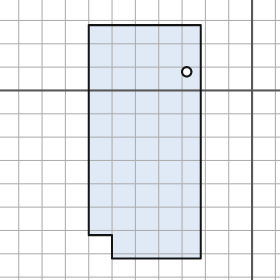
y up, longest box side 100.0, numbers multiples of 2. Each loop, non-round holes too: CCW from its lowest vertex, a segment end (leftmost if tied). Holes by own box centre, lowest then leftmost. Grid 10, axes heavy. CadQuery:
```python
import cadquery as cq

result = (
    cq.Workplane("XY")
    .moveTo(-60.0, -72.0)
    .lineTo(-22.0, -72.0)
    .lineTo(-22.0, 28.0)
    .lineTo(-70.0, 28.0)
    .lineTo(-70.0, -62.0)
    .lineTo(-60.0, -62.0)
    .close()
    .moveTo(-28.0, 8.0)
    .circle(2.0)
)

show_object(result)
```